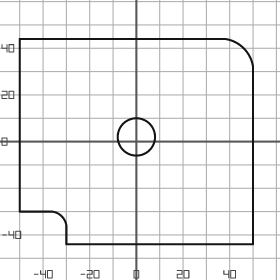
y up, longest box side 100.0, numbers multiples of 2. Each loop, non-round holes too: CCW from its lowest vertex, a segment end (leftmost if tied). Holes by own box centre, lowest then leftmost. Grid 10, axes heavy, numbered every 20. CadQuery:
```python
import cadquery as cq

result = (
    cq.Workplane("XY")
    .moveTo(-30.0, -44.0)
    .lineTo(50.0, -44.0)
    .lineTo(50.0, 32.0)
    .threePointArc((46.0, 40.0), (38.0, 44.0))
    .lineTo(-50.0, 44.0)
    .lineTo(-50.0, -30.0)
    .lineTo(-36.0, -30.0)
    .threePointArc((-32.0, -32.0), (-30.0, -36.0))
    .close()
    .moveTo(0.0, 2.0)
    .circle(8.0)
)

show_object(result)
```